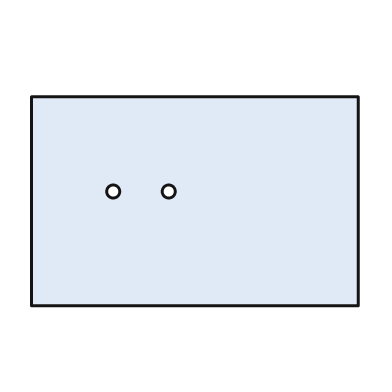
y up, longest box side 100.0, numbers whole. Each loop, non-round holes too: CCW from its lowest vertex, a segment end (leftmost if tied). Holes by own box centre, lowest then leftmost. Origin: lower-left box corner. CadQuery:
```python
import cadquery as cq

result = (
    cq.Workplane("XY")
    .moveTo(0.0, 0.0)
    .lineTo(100.0, 0.0)
    .lineTo(100.0, 64.0)
    .lineTo(0.0, 64.0)
    .close()
    .moveTo(25.0, 35.0)
    .circle(2.0)
    .moveTo(42.0, 35.0)
    .circle(2.0)
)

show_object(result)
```